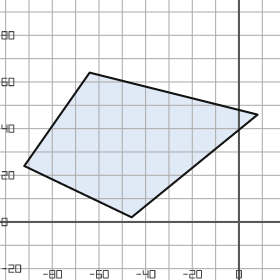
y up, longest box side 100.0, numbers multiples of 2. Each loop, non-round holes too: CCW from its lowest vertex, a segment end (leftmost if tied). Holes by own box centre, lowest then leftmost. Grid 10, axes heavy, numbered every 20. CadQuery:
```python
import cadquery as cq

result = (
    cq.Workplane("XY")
    .moveTo(-46.0, 2.0)
    .lineTo(8.0, 46.0)
    .lineTo(-64.0, 64.0)
    .lineTo(-92.0, 24.0)
    .close()
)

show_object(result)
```